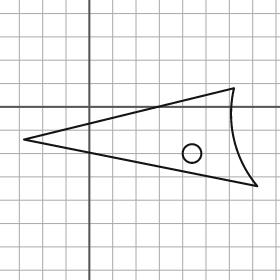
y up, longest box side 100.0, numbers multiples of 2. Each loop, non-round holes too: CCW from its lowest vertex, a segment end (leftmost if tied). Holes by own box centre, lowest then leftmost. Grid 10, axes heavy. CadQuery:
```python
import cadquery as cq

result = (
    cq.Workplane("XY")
    .moveTo(72.0, -34.0)
    .threePointArc((62.0, -14.0), (62.0, 8.0))
    .lineTo(-28.0, -14.0)
    .close()
    .moveTo(44.0, -20.0)
    .circle(4.0)
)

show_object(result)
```